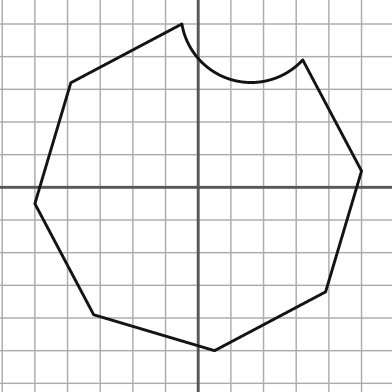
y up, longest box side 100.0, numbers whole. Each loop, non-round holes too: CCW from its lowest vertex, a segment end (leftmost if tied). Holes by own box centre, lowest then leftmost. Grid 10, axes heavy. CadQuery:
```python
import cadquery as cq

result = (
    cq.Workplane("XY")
    .moveTo(5.0, -50.0)
    .lineTo(39.0, -32.0)
    .lineTo(50.0, 5.0)
    .lineTo(32.0, 39.0)
    .threePointArc((10.0, 33.0), (-5.0, 50.0))
    .lineTo(-39.0, 32.0)
    .lineTo(-50.0, -5.0)
    .lineTo(-32.0, -39.0)
    .close()
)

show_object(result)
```